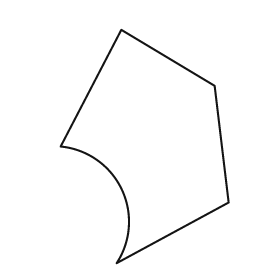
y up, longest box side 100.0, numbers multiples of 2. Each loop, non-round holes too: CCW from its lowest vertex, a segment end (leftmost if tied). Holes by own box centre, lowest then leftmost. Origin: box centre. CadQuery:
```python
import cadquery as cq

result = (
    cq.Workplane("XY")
    .moveTo(-12.0, -50.0)
    .lineTo(36.0, -24.0)
    .lineTo(30.0, 26.0)
    .lineTo(-10.0, 50.0)
    .lineTo(-36.0, 0.0)
    .threePointArc((-10.0, -18.0), (-12.0, -50.0))
    .close()
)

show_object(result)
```